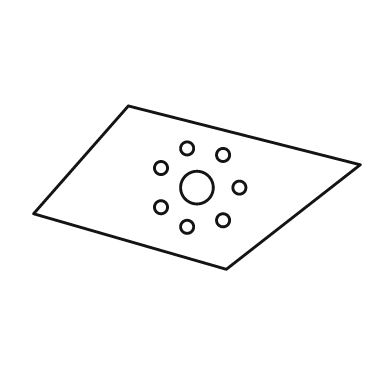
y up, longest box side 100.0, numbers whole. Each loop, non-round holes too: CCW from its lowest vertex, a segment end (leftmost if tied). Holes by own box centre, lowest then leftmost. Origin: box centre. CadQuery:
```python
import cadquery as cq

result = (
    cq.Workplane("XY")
    .moveTo(9.0, -25.0)
    .lineTo(50.0, 7.0)
    .lineTo(-21.0, 25.0)
    .lineTo(-50.0, -8.0)
    .close()
    .moveTo(-3.0, -12.0)
    .circle(2.0)
    .moveTo(8.0, -10.0)
    .circle(2.0)
    .moveTo(-11.0, -6.0)
    .circle(2.0)
    .moveTo(0.0, 0.0)
    .circle(5.0)
    .moveTo(13.0, 0.0)
    .circle(2.0)
    .moveTo(-11.0, 6.0)
    .circle(2.0)
    .moveTo(8.0, 10.0)
    .circle(2.0)
    .moveTo(-3.0, 12.0)
    .circle(2.0)
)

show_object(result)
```